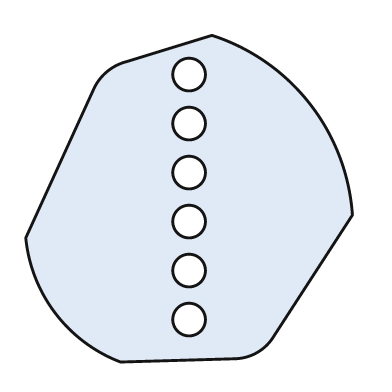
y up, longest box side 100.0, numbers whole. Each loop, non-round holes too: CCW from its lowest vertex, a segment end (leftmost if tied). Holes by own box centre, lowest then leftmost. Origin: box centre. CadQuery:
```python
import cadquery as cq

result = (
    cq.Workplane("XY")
    .moveTo(-21.0, -50.0)
    .lineTo(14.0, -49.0)
    .threePointArc((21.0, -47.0), (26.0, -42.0))
    .lineTo(50.0, -5.0)
    .threePointArc((37.0, 29.0), (7.0, 50.0))
    .lineTo(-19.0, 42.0)
    .threePointArc((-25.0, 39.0), (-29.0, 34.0))
    .lineTo(-50.0, -12.0)
    .threePointArc((-41.0, -35.0), (-21.0, -50.0))
    .close()
    .moveTo(0.0, -37.0)
    .circle(5.0)
    .moveTo(0.0, -22.0)
    .circle(5.0)
    .moveTo(0.0, -7.0)
    .circle(5.0)
    .moveTo(0.0, 8.0)
    .circle(5.0)
    .moveTo(0.0, 23.0)
    .circle(5.0)
    .moveTo(0.0, 38.0)
    .circle(5.0)
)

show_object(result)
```